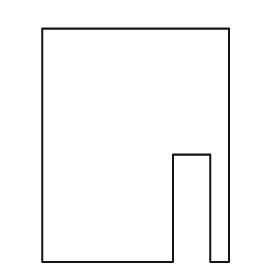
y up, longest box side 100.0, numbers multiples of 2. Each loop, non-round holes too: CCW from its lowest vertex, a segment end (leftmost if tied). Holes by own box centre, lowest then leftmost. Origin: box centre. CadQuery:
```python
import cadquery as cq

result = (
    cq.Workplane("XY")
    .moveTo(-40.0, -50.0)
    .lineTo(16.0, -50.0)
    .lineTo(16.0, -4.0)
    .lineTo(32.0, -4.0)
    .lineTo(32.0, -50.0)
    .lineTo(40.0, -50.0)
    .lineTo(40.0, 50.0)
    .lineTo(-40.0, 50.0)
    .close()
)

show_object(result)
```